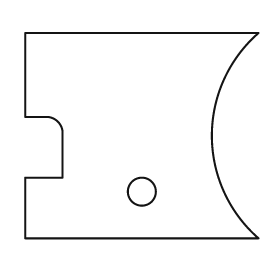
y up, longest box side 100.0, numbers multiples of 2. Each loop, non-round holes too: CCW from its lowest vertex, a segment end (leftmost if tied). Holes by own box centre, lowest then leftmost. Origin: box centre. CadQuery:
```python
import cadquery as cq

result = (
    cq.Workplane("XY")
    .moveTo(-50.0, -44.0)
    .lineTo(50.0, -44.0)
    .threePointArc((30.0, 0.0), (50.0, 44.0))
    .lineTo(-50.0, 44.0)
    .lineTo(-50.0, 8.0)
    .lineTo(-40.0, 8.0)
    .threePointArc((-36.0, 6.0), (-34.0, 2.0))
    .lineTo(-34.0, -18.0)
    .lineTo(-50.0, -18.0)
    .close()
    .moveTo(0.0, -24.0)
    .circle(6.0)
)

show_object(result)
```